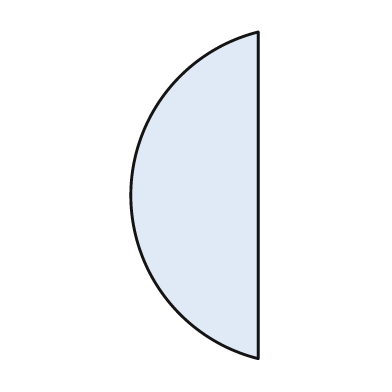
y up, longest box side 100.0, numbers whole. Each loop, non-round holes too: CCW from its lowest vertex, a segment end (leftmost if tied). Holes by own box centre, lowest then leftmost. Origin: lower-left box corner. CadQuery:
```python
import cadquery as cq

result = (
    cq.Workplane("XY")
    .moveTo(39.0, 0.0)
    .lineTo(39.0, 100.0)
    .threePointArc((0.0, 50.0), (39.0, 0.0))
    .close()
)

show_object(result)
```